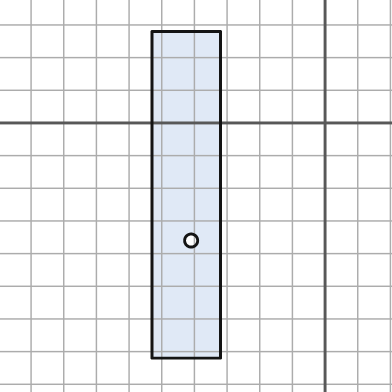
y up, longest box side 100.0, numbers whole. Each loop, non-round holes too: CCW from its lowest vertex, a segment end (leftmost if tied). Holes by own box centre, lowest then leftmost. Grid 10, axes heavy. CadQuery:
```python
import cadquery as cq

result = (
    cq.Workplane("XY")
    .moveTo(-53.0, -72.0)
    .lineTo(-32.0, -72.0)
    .lineTo(-32.0, 28.0)
    .lineTo(-53.0, 28.0)
    .close()
    .moveTo(-41.0, -36.0)
    .circle(2.0)
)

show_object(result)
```